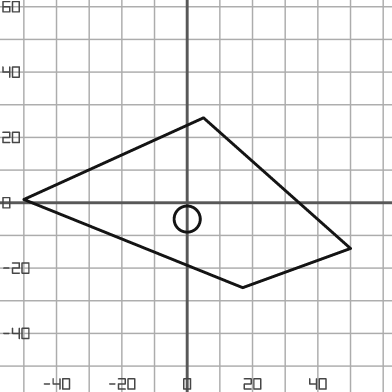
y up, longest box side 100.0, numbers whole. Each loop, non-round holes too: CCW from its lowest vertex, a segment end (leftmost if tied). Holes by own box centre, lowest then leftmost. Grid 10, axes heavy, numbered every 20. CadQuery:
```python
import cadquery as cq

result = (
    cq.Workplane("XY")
    .moveTo(17.0, -26.0)
    .lineTo(50.0, -14.0)
    .lineTo(5.0, 26.0)
    .lineTo(-50.0, 1.0)
    .close()
    .moveTo(0.0, -5.0)
    .circle(4.0)
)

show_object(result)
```